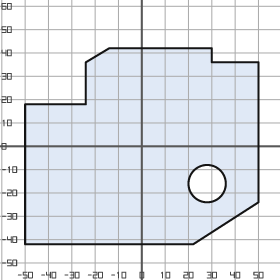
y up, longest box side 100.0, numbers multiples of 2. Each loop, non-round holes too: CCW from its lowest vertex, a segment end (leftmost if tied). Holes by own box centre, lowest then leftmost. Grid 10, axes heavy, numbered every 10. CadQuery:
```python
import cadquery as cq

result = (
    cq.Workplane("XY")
    .moveTo(-50.0, -42.0)
    .lineTo(22.0, -42.0)
    .lineTo(50.0, -24.0)
    .lineTo(50.0, 36.0)
    .lineTo(30.0, 36.0)
    .lineTo(30.0, 42.0)
    .lineTo(-14.0, 42.0)
    .lineTo(-24.0, 36.0)
    .lineTo(-24.0, 18.0)
    .lineTo(-50.0, 18.0)
    .close()
    .moveTo(28.0, -16.0)
    .circle(8.0)
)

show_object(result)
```